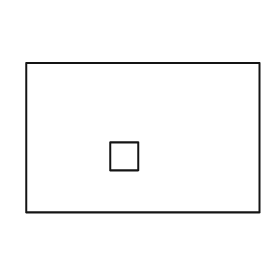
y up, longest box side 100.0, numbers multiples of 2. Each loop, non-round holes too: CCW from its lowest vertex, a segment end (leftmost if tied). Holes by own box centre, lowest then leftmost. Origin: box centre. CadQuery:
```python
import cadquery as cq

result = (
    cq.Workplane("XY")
    .moveTo(-50.0, -32.0)
    .lineTo(50.0, -32.0)
    .lineTo(50.0, 32.0)
    .lineTo(-50.0, 32.0)
    .close()
    .moveTo(-14.0, -14.0)
    .lineTo(-2.0, -14.0)
    .lineTo(-2.0, -2.0)
    .lineTo(-14.0, -2.0)
    .close()
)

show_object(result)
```